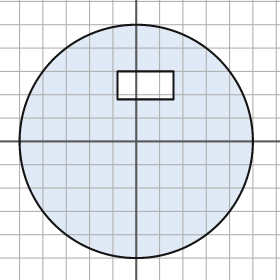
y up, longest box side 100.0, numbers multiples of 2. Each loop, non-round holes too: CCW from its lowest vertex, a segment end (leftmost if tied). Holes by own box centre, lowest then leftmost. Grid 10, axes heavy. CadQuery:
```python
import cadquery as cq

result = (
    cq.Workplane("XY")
    .moveTo(0.0, 0.0)
    .circle(50.0)
    .moveTo(-8.0, 18.0)
    .lineTo(16.0, 18.0)
    .lineTo(16.0, 30.0)
    .lineTo(-8.0, 30.0)
    .close()
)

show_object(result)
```